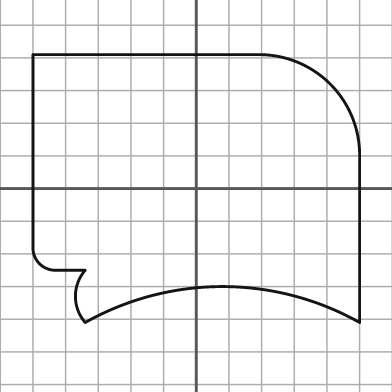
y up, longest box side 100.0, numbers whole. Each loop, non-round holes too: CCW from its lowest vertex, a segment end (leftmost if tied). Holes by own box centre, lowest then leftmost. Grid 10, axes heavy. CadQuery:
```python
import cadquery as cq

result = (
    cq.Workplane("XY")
    .moveTo(-34.0, -41.0)
    .threePointArc((8.0, -30.0), (50.0, -41.0))
    .lineTo(50.0, 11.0)
    .threePointArc((41.0, 32.0), (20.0, 41.0))
    .lineTo(-50.0, 41.0)
    .lineTo(-50.0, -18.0)
    .threePointArc((-48.0, -23.0), (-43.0, -25.0))
    .lineTo(-34.0, -25.0)
    .threePointArc((-37.0, -33.0), (-34.0, -41.0))
    .close()
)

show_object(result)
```